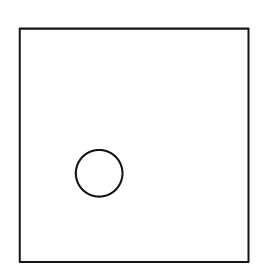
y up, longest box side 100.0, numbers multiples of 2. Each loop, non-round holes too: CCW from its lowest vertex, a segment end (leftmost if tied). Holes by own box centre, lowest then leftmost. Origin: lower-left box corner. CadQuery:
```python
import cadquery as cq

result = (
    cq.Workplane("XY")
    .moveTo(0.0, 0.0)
    .lineTo(98.0, 0.0)
    .lineTo(98.0, 100.0)
    .lineTo(0.0, 100.0)
    .close()
    .moveTo(34.0, 38.0)
    .circle(10.0)
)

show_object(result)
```